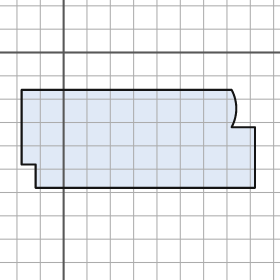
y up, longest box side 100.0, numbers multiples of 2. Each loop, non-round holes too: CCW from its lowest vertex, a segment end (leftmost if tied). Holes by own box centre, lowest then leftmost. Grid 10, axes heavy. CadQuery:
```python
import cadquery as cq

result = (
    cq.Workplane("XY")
    .moveTo(-12.0, -58.0)
    .lineTo(82.0, -58.0)
    .lineTo(82.0, -32.0)
    .lineTo(72.0, -32.0)
    .threePointArc((74.0, -24.0), (72.0, -16.0))
    .lineTo(-18.0, -16.0)
    .lineTo(-18.0, -48.0)
    .lineTo(-12.0, -48.0)
    .close()
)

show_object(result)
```